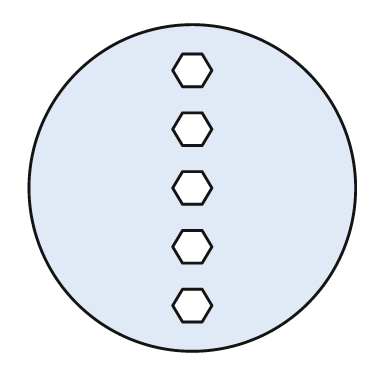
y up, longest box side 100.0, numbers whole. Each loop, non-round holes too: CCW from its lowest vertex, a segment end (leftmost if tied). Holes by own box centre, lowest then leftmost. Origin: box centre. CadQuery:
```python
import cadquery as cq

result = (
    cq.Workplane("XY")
    .moveTo(0.0, 0.0)
    .circle(50.0)
    .moveTo(-3.0, -41.0)
    .lineTo(3.0, -41.0)
    .lineTo(6.0, -36.0)
    .lineTo(3.0, -31.0)
    .lineTo(-3.0, -31.0)
    .lineTo(-6.0, -36.0)
    .close()
    .moveTo(-3.0, -23.0)
    .lineTo(3.0, -23.0)
    .lineTo(6.0, -18.0)
    .lineTo(3.0, -13.0)
    .lineTo(-3.0, -13.0)
    .lineTo(-6.0, -18.0)
    .close()
    .moveTo(-3.0, -5.0)
    .lineTo(3.0, -5.0)
    .lineTo(6.0, 0.0)
    .lineTo(3.0, 5.0)
    .lineTo(-3.0, 5.0)
    .lineTo(-6.0, 0.0)
    .close()
    .moveTo(-3.0, 13.0)
    .lineTo(3.0, 13.0)
    .lineTo(6.0, 18.0)
    .lineTo(3.0, 23.0)
    .lineTo(-3.0, 23.0)
    .lineTo(-6.0, 18.0)
    .close()
    .moveTo(-3.0, 31.0)
    .lineTo(3.0, 31.0)
    .lineTo(6.0, 36.0)
    .lineTo(3.0, 41.0)
    .lineTo(-3.0, 41.0)
    .lineTo(-6.0, 36.0)
    .close()
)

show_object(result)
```